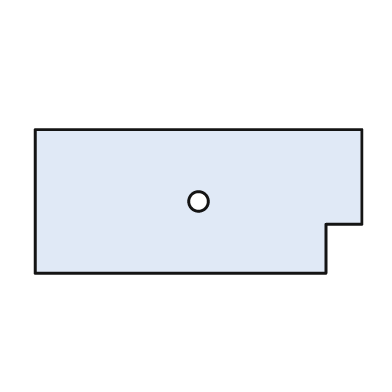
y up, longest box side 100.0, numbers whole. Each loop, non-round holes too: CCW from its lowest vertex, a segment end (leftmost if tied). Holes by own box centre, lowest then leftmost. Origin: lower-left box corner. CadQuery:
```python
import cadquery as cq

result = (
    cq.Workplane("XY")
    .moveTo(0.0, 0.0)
    .lineTo(89.0, 0.0)
    .lineTo(89.0, 15.0)
    .lineTo(100.0, 15.0)
    .lineTo(100.0, 44.0)
    .lineTo(0.0, 44.0)
    .close()
    .moveTo(50.0, 22.0)
    .circle(3.0)
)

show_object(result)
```